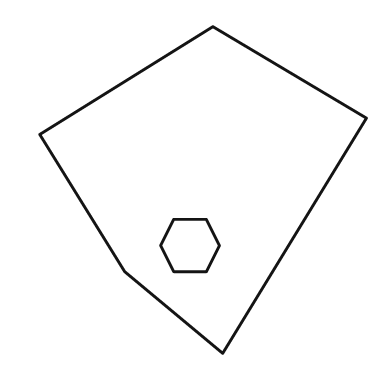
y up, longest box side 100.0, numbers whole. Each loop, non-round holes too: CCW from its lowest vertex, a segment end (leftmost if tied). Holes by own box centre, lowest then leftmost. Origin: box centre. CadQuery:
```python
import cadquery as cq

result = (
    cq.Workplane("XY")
    .moveTo(6.0, -50.0)
    .lineTo(50.0, 22.0)
    .lineTo(3.0, 50.0)
    .lineTo(-50.0, 17.0)
    .lineTo(-24.0, -25.0)
    .close()
    .moveTo(-9.0, -25.0)
    .lineTo(1.0, -25.0)
    .lineTo(5.0, -17.0)
    .lineTo(1.0, -9.0)
    .lineTo(-9.0, -9.0)
    .lineTo(-13.0, -17.0)
    .close()
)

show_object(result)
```